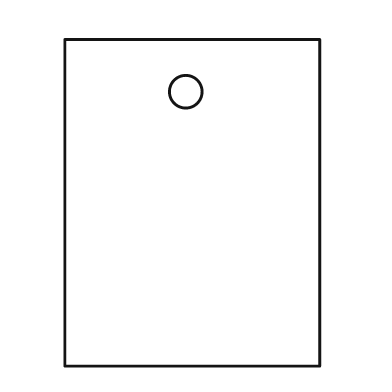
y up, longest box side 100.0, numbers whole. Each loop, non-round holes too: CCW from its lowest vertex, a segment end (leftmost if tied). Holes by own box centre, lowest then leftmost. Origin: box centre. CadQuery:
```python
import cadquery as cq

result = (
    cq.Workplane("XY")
    .moveTo(-39.0, -50.0)
    .lineTo(39.0, -50.0)
    .lineTo(39.0, 50.0)
    .lineTo(-39.0, 50.0)
    .close()
    .moveTo(-2.0, 34.0)
    .circle(5.0)
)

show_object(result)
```